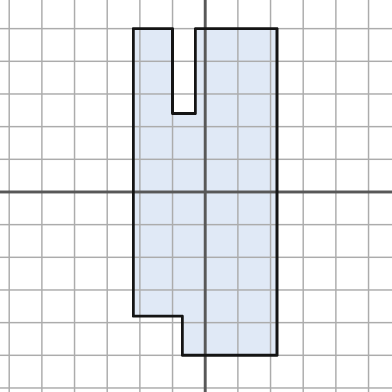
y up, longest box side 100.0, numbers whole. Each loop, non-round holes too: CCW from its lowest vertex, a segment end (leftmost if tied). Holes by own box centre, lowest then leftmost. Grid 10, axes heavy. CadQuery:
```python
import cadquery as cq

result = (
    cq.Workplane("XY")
    .moveTo(-7.0, -50.0)
    .lineTo(22.0, -50.0)
    .lineTo(22.0, 50.0)
    .lineTo(-3.0, 50.0)
    .lineTo(-3.0, 24.0)
    .lineTo(-10.0, 24.0)
    .lineTo(-10.0, 50.0)
    .lineTo(-22.0, 50.0)
    .lineTo(-22.0, -38.0)
    .lineTo(-7.0, -38.0)
    .close()
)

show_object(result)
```